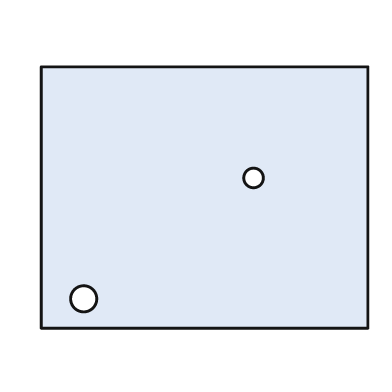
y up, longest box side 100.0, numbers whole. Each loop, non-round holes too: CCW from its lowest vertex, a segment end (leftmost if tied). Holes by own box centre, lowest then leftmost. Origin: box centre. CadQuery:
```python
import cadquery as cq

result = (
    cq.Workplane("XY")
    .moveTo(-50.0, -40.0)
    .lineTo(50.0, -40.0)
    .lineTo(50.0, 40.0)
    .lineTo(-50.0, 40.0)
    .close()
    .moveTo(-37.0, -31.0)
    .circle(4.0)
    .moveTo(15.0, 6.0)
    .circle(3.0)
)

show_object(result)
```